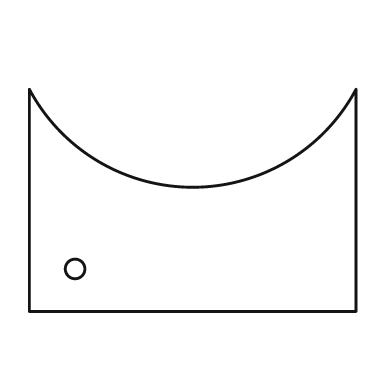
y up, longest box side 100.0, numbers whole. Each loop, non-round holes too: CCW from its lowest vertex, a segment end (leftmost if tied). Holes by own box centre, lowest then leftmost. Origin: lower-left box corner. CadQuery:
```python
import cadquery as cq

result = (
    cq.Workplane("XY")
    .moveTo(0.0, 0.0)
    .lineTo(100.0, 0.0)
    .lineTo(100.0, 68.0)
    .threePointArc((50.0, 38.0), (0.0, 68.0))
    .close()
    .moveTo(14.0, 13.0)
    .circle(3.0)
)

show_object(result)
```